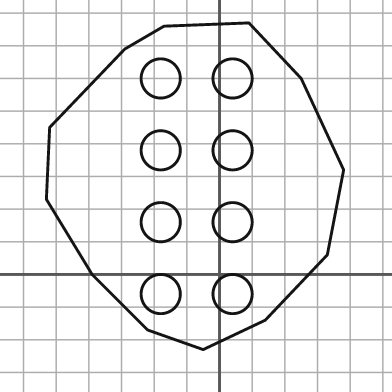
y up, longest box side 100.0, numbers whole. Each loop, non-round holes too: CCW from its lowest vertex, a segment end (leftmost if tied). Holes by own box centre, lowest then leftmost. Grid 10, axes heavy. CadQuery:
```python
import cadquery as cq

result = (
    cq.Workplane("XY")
    .moveTo(-5.0, -23.0)
    .lineTo(14.0, -14.0)
    .lineTo(33.0, 6.0)
    .lineTo(38.0, 32.0)
    .lineTo(25.0, 60.0)
    .lineTo(9.0, 77.0)
    .lineTo(-17.0, 76.0)
    .lineTo(-29.0, 69.0)
    .lineTo(-52.0, 45.0)
    .lineTo(-53.0, 23.0)
    .lineTo(-39.0, 0.0)
    .lineTo(-22.0, -17.0)
    .close()
    .moveTo(-18.0, -6.0)
    .circle(6.0)
    .moveTo(4.0, -6.0)
    .circle(6.0)
    .moveTo(-18.0, 16.0)
    .circle(6.0)
    .moveTo(4.0, 16.0)
    .circle(6.0)
    .moveTo(-18.0, 38.0)
    .circle(6.0)
    .moveTo(4.0, 38.0)
    .circle(6.0)
    .moveTo(-18.0, 60.0)
    .circle(6.0)
    .moveTo(4.0, 60.0)
    .circle(6.0)
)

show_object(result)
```